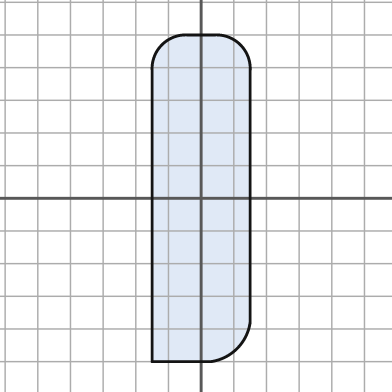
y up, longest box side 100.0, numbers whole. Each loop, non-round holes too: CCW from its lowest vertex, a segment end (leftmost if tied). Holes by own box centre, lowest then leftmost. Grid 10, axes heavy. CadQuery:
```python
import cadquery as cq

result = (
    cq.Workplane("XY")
    .moveTo(-15.0, -50.0)
    .lineTo(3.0, -50.0)
    .threePointArc((11.0, -46.0), (15.0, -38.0))
    .lineTo(15.0, 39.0)
    .threePointArc((12.0, 47.0), (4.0, 50.0))
    .lineTo(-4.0, 50.0)
    .threePointArc((-12.0, 47.0), (-15.0, 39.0))
    .close()
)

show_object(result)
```